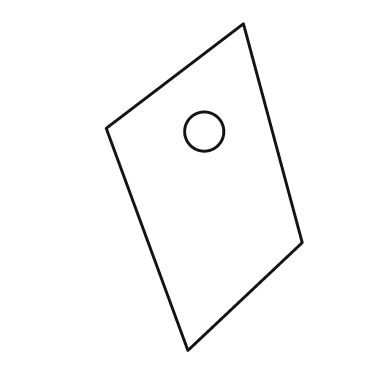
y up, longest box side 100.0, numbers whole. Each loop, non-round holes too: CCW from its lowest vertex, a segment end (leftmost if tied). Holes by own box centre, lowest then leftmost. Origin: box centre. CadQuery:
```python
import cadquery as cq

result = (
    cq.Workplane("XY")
    .moveTo(-5.0, -50.0)
    .lineTo(30.0, -17.0)
    .lineTo(12.0, 50.0)
    .lineTo(-30.0, 18.0)
    .close()
    .moveTo(0.0, 17.0)
    .circle(6.0)
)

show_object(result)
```